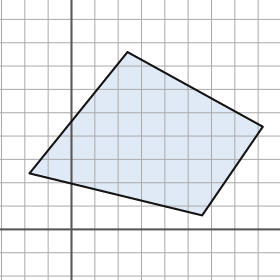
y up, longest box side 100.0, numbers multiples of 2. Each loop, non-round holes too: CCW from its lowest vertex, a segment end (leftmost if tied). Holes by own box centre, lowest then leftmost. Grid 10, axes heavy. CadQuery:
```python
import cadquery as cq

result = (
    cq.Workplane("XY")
    .moveTo(56.0, 6.0)
    .lineTo(82.0, 44.0)
    .lineTo(24.0, 76.0)
    .lineTo(-18.0, 24.0)
    .close()
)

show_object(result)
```